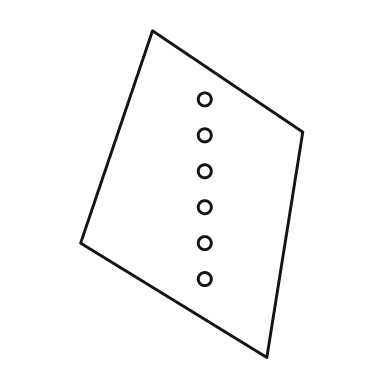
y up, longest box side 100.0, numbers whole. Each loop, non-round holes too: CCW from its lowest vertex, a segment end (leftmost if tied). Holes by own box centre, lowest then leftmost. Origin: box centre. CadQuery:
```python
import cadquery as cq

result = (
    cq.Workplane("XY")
    .moveTo(23.0, -50.0)
    .lineTo(34.0, 19.0)
    .lineTo(-12.0, 50.0)
    .lineTo(-34.0, -15.0)
    .close()
    .moveTo(4.0, -26.0)
    .circle(2.0)
    .moveTo(4.0, -15.0)
    .circle(2.0)
    .moveTo(4.0, -4.0)
    .circle(2.0)
    .moveTo(4.0, 7.0)
    .circle(2.0)
    .moveTo(4.0, 18.0)
    .circle(2.0)
    .moveTo(4.0, 29.0)
    .circle(2.0)
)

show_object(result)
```